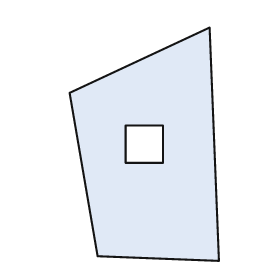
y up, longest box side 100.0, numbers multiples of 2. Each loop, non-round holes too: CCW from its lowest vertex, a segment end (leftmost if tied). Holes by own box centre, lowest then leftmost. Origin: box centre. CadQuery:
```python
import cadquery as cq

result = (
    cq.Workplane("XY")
    .moveTo(32.0, -50.0)
    .lineTo(28.0, 50.0)
    .lineTo(-32.0, 22.0)
    .lineTo(-20.0, -48.0)
    .close()
    .moveTo(-8.0, -8.0)
    .lineTo(8.0, -8.0)
    .lineTo(8.0, 8.0)
    .lineTo(-8.0, 8.0)
    .close()
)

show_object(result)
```